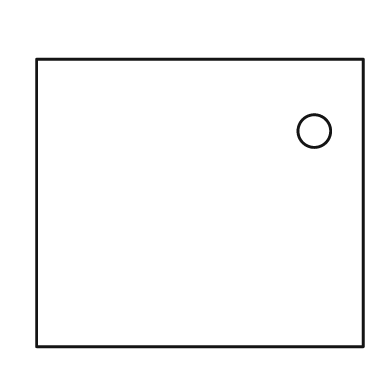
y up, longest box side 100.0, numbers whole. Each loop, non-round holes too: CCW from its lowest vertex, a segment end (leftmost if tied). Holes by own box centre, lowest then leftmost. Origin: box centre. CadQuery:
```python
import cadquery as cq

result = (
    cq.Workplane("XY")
    .moveTo(-50.0, -44.0)
    .lineTo(50.0, -44.0)
    .lineTo(50.0, 44.0)
    .lineTo(-50.0, 44.0)
    .close()
    .moveTo(35.0, 22.0)
    .circle(5.0)
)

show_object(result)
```